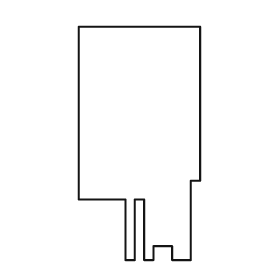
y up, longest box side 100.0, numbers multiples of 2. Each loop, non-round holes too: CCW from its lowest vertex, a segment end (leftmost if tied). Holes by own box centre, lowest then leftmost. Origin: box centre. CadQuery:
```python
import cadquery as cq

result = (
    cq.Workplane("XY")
    .moveTo(-6.0, -50.0)
    .lineTo(-2.0, -50.0)
    .lineTo(-2.0, -24.0)
    .lineTo(2.0, -24.0)
    .lineTo(2.0, -50.0)
    .lineTo(6.0, -50.0)
    .lineTo(6.0, -44.0)
    .lineTo(14.0, -44.0)
    .lineTo(14.0, -50.0)
    .lineTo(22.0, -50.0)
    .lineTo(22.0, -16.0)
    .lineTo(26.0, -16.0)
    .lineTo(26.0, 50.0)
    .lineTo(-26.0, 50.0)
    .lineTo(-26.0, -24.0)
    .lineTo(-6.0, -24.0)
    .close()
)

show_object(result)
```